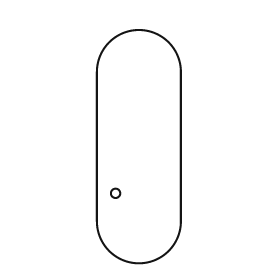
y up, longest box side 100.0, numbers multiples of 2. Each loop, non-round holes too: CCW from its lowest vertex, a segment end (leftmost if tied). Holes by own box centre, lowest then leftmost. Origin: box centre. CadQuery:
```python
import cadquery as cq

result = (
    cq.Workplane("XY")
    .moveTo(-18.0, -32.0)
    .threePointArc((0.0, -50.0), (18.0, -32.0))
    .lineTo(18.0, 32.0)
    .threePointArc((0.0, 50.0), (-18.0, 32.0))
    .close()
    .moveTo(-10.0, -20.0)
    .circle(2.0)
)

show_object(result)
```